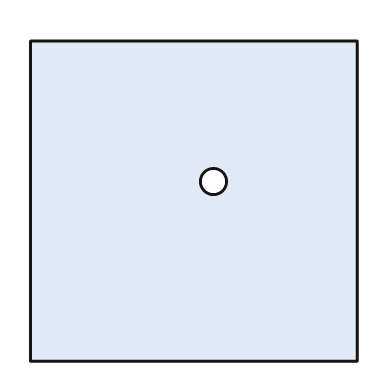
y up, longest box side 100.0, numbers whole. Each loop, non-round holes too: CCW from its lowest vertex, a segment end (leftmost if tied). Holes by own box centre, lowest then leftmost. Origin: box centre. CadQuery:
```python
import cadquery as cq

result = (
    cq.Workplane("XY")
    .moveTo(-50.0, -49.0)
    .lineTo(50.0, -49.0)
    .lineTo(50.0, 49.0)
    .lineTo(-50.0, 49.0)
    .close()
    .moveTo(6.0, 6.0)
    .circle(4.0)
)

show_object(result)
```